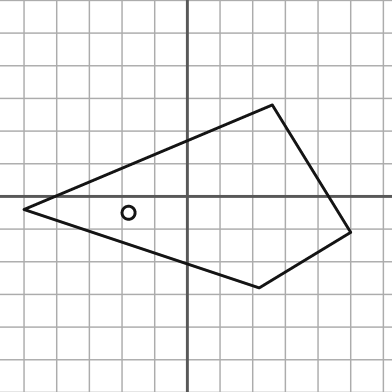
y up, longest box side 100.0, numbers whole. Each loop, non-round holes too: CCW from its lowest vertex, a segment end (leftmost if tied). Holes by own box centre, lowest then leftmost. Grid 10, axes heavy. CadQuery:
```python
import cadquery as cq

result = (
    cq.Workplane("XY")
    .moveTo(22.0, -28.0)
    .lineTo(50.0, -11.0)
    .lineTo(26.0, 28.0)
    .lineTo(-50.0, -4.0)
    .close()
    .moveTo(-18.0, -5.0)
    .circle(2.0)
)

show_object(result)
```